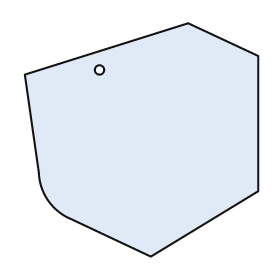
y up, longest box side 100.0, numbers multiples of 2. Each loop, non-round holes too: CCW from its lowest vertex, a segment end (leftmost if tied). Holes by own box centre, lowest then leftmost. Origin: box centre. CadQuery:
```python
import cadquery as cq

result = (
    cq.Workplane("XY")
    .moveTo(4.0, -50.0)
    .lineTo(50.0, -22.0)
    .lineTo(50.0, 36.0)
    .lineTo(20.0, 50.0)
    .lineTo(-50.0, 28.0)
    .lineTo(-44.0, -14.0)
    .threePointArc((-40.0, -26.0), (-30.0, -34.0))
    .close()
    .moveTo(-18.0, 30.0)
    .circle(2.0)
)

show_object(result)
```